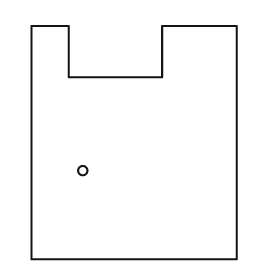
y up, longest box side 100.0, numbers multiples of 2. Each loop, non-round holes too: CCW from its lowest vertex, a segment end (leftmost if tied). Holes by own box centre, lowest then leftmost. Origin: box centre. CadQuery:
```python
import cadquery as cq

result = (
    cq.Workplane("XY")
    .moveTo(-44.0, -50.0)
    .lineTo(44.0, -50.0)
    .lineTo(44.0, 50.0)
    .lineTo(12.0, 50.0)
    .lineTo(12.0, 28.0)
    .lineTo(-28.0, 28.0)
    .lineTo(-28.0, 50.0)
    .lineTo(-44.0, 50.0)
    .close()
    .moveTo(-22.0, -12.0)
    .circle(2.0)
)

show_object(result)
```